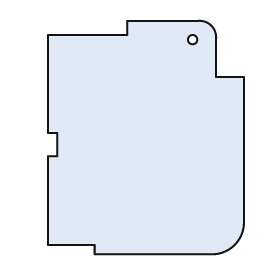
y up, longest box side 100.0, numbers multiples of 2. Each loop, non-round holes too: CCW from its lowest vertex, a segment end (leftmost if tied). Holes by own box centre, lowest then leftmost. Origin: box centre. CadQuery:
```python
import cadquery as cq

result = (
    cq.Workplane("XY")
    .moveTo(-22.0, -50.0)
    .lineTo(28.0, -50.0)
    .threePointArc((38.0, -46.0), (42.0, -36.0))
    .lineTo(42.0, 26.0)
    .lineTo(30.0, 26.0)
    .lineTo(30.0, 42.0)
    .threePointArc((28.0, 48.0), (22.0, 50.0))
    .lineTo(-8.0, 50.0)
    .lineTo(-8.0, 44.0)
    .lineTo(-42.0, 44.0)
    .lineTo(-42.0, 2.0)
    .lineTo(-38.0, 2.0)
    .lineTo(-38.0, -8.0)
    .lineTo(-42.0, -8.0)
    .lineTo(-42.0, -46.0)
    .lineTo(-22.0, -46.0)
    .close()
    .moveTo(20.0, 42.0)
    .circle(2.0)
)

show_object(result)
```